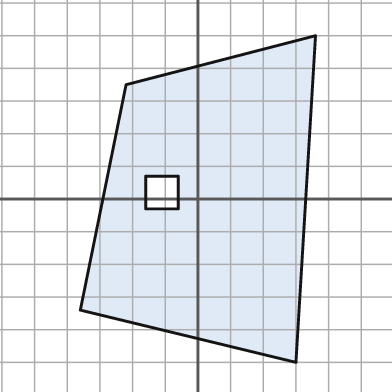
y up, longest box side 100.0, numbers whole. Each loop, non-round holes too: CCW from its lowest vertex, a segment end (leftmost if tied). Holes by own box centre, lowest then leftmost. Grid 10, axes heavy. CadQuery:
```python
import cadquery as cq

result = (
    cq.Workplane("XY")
    .moveTo(30.0, -50.0)
    .lineTo(36.0, 50.0)
    .lineTo(-22.0, 35.0)
    .lineTo(-36.0, -34.0)
    .close()
    .moveTo(-16.0, -3.0)
    .lineTo(-6.0, -3.0)
    .lineTo(-6.0, 7.0)
    .lineTo(-16.0, 7.0)
    .close()
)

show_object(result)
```